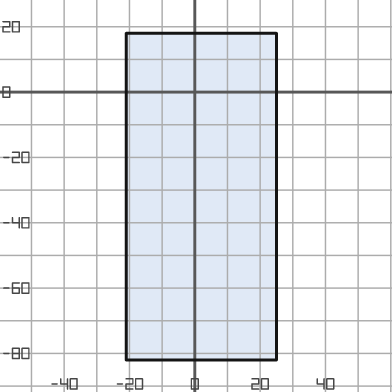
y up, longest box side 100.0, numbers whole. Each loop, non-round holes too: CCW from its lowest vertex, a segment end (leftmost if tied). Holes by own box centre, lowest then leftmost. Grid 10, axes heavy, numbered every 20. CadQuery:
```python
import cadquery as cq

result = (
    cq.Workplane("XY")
    .moveTo(-21.0, -82.0)
    .lineTo(25.0, -82.0)
    .lineTo(25.0, 18.0)
    .lineTo(-21.0, 18.0)
    .close()
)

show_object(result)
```